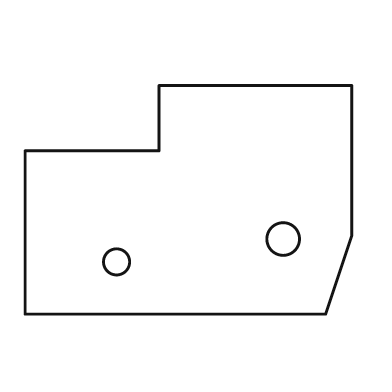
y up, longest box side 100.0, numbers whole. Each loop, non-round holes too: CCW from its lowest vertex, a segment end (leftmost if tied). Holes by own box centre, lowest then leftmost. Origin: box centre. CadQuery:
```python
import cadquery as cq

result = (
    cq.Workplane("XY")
    .moveTo(-50.0, -35.0)
    .lineTo(42.0, -35.0)
    .lineTo(50.0, -11.0)
    .lineTo(50.0, 35.0)
    .lineTo(-9.0, 35.0)
    .lineTo(-9.0, 15.0)
    .lineTo(-50.0, 15.0)
    .close()
    .moveTo(-22.0, -19.0)
    .circle(4.0)
    .moveTo(29.0, -12.0)
    .circle(5.0)
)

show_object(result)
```